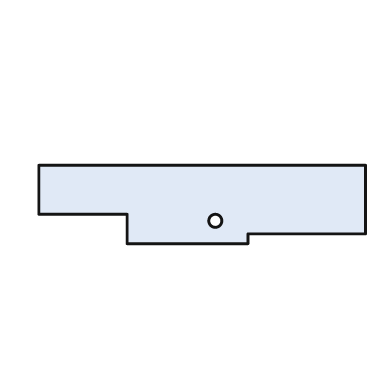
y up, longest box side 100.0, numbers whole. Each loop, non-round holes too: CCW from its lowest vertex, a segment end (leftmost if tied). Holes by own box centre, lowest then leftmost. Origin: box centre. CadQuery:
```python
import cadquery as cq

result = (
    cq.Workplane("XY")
    .moveTo(-23.0, -12.0)
    .lineTo(14.0, -12.0)
    .lineTo(14.0, -9.0)
    .lineTo(50.0, -9.0)
    .lineTo(50.0, 12.0)
    .lineTo(-50.0, 12.0)
    .lineTo(-50.0, -3.0)
    .lineTo(-23.0, -3.0)
    .close()
    .moveTo(4.0, -5.0)
    .circle(2.0)
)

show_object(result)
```